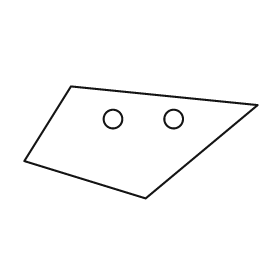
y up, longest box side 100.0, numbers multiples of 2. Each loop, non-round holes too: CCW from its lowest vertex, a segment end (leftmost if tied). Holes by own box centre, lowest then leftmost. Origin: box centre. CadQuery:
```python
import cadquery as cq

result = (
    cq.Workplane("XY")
    .moveTo(2.0, -24.0)
    .lineTo(50.0, 16.0)
    .lineTo(-30.0, 24.0)
    .lineTo(-50.0, -8.0)
    .close()
    .moveTo(-12.0, 10.0)
    .circle(4.0)
    .moveTo(14.0, 10.0)
    .circle(4.0)
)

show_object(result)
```